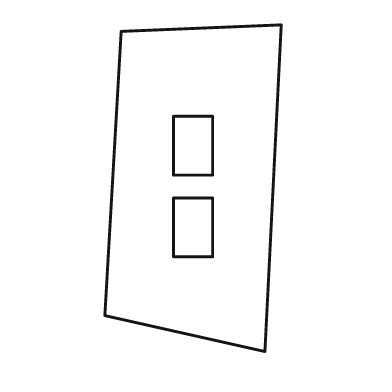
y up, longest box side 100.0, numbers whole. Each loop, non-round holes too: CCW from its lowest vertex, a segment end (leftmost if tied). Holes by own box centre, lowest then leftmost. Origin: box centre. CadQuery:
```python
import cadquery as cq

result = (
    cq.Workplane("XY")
    .moveTo(22.0, -50.0)
    .lineTo(27.0, 50.0)
    .lineTo(-22.0, 48.0)
    .lineTo(-27.0, -39.0)
    .close()
    .moveTo(-6.0, -21.0)
    .lineTo(6.0, -21.0)
    .lineTo(6.0, -3.0)
    .lineTo(-6.0, -3.0)
    .close()
    .moveTo(-6.0, 4.0)
    .lineTo(6.0, 4.0)
    .lineTo(6.0, 22.0)
    .lineTo(-6.0, 22.0)
    .close()
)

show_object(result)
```